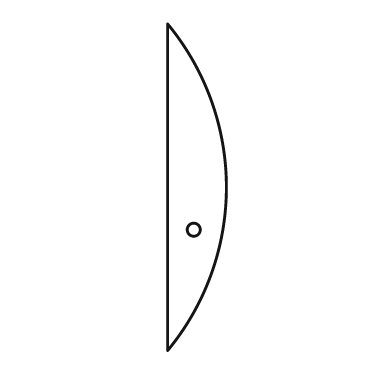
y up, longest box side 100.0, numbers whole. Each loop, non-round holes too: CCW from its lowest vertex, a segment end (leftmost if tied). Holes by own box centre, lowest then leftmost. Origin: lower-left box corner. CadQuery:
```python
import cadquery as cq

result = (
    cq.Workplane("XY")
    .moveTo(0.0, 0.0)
    .threePointArc((18.0, 50.0), (0.0, 100.0))
    .close()
    .moveTo(8.0, 37.0)
    .circle(2.0)
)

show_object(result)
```